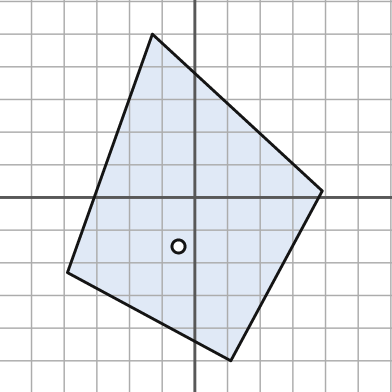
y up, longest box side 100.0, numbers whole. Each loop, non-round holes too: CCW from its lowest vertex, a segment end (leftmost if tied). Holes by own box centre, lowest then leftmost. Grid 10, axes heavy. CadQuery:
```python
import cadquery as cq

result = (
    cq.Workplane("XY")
    .moveTo(11.0, -50.0)
    .lineTo(39.0, 2.0)
    .lineTo(-13.0, 50.0)
    .lineTo(-39.0, -23.0)
    .close()
    .moveTo(-5.0, -15.0)
    .circle(2.0)
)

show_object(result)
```